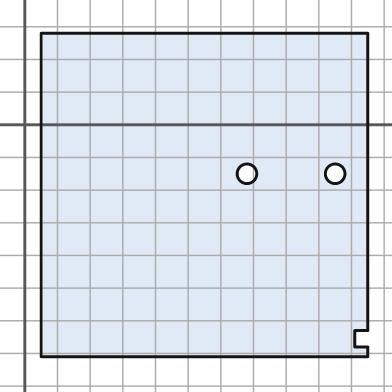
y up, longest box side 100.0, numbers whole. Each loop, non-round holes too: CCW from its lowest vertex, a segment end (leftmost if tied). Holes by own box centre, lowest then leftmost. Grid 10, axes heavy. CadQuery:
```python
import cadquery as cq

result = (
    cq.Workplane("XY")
    .moveTo(5.0, -71.0)
    .lineTo(105.0, -71.0)
    .lineTo(105.0, -68.0)
    .lineTo(101.0, -68.0)
    .lineTo(101.0, -63.0)
    .lineTo(105.0, -63.0)
    .lineTo(105.0, 28.0)
    .lineTo(5.0, 28.0)
    .close()
    .moveTo(68.0, -15.0)
    .circle(3.0)
    .moveTo(95.0, -15.0)
    .circle(3.0)
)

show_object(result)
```